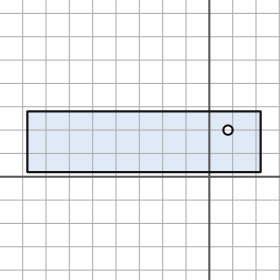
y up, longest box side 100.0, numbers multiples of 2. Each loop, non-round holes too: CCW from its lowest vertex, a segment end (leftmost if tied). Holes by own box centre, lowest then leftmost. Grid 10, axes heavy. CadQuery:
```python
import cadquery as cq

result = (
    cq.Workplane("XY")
    .moveTo(-78.0, 2.0)
    .lineTo(22.0, 2.0)
    .lineTo(22.0, 28.0)
    .lineTo(-78.0, 28.0)
    .close()
    .moveTo(8.0, 20.0)
    .circle(2.0)
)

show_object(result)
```